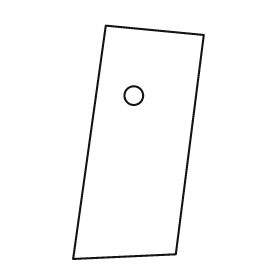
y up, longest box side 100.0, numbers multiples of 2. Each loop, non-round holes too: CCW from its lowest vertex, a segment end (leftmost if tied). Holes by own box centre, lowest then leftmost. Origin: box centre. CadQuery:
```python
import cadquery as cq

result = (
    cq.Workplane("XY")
    .moveTo(-28.0, -50.0)
    .lineTo(16.0, -48.0)
    .lineTo(28.0, 46.0)
    .lineTo(-14.0, 50.0)
    .close()
    .moveTo(-2.0, 20.0)
    .circle(4.0)
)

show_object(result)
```